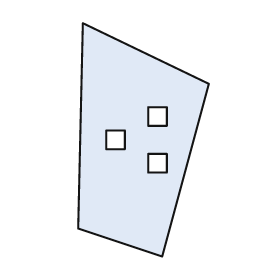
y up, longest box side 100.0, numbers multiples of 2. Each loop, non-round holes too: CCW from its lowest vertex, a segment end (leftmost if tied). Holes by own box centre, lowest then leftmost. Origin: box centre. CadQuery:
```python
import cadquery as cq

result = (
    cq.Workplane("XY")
    .moveTo(8.0, -50.0)
    .lineTo(28.0, 24.0)
    .lineTo(-26.0, 50.0)
    .lineTo(-28.0, -38.0)
    .close()
    .moveTo(2.0, -14.0)
    .lineTo(10.0, -14.0)
    .lineTo(10.0, -6.0)
    .lineTo(2.0, -6.0)
    .close()
    .moveTo(-16.0, -4.0)
    .lineTo(-8.0, -4.0)
    .lineTo(-8.0, 4.0)
    .lineTo(-16.0, 4.0)
    .close()
    .moveTo(2.0, 6.0)
    .lineTo(10.0, 6.0)
    .lineTo(10.0, 14.0)
    .lineTo(2.0, 14.0)
    .close()
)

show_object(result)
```